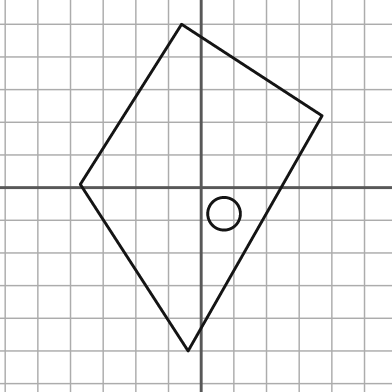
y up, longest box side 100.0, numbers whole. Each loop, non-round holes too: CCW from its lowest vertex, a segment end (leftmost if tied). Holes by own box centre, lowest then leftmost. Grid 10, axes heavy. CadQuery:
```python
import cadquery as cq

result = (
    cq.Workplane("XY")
    .moveTo(-4.0, -50.0)
    .lineTo(37.0, 22.0)
    .lineTo(-6.0, 50.0)
    .lineTo(-37.0, 1.0)
    .close()
    .moveTo(7.0, -8.0)
    .circle(5.0)
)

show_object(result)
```